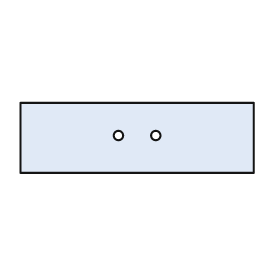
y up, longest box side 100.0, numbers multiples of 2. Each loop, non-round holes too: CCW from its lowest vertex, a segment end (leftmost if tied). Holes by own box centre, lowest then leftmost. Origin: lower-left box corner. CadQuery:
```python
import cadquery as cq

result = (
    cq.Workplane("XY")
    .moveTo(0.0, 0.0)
    .lineTo(100.0, 0.0)
    .lineTo(100.0, 30.0)
    .lineTo(0.0, 30.0)
    .close()
    .moveTo(42.0, 16.0)
    .circle(2.0)
    .moveTo(58.0, 16.0)
    .circle(2.0)
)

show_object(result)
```